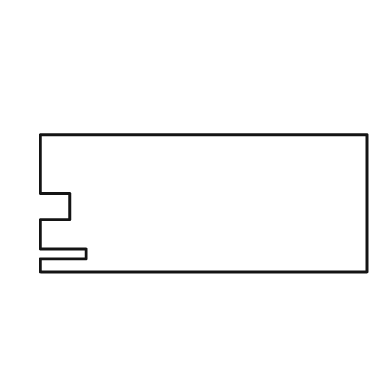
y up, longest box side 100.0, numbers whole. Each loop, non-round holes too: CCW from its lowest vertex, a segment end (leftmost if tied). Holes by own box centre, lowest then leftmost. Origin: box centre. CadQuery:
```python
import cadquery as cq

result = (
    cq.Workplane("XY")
    .moveTo(-50.0, -21.0)
    .lineTo(50.0, -21.0)
    .lineTo(50.0, 21.0)
    .lineTo(-50.0, 21.0)
    .lineTo(-50.0, 3.0)
    .lineTo(-41.0, 3.0)
    .lineTo(-41.0, -5.0)
    .lineTo(-50.0, -5.0)
    .lineTo(-50.0, -14.0)
    .lineTo(-36.0, -14.0)
    .lineTo(-36.0, -17.0)
    .lineTo(-50.0, -17.0)
    .close()
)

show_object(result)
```